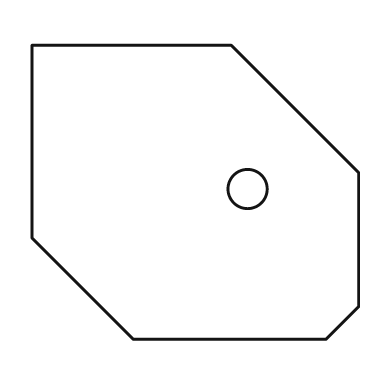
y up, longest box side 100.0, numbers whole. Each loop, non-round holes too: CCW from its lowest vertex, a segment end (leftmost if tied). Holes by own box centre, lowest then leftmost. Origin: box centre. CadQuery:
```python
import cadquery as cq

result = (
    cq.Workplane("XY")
    .moveTo(-19.0, -45.0)
    .lineTo(40.0, -45.0)
    .lineTo(50.0, -35.0)
    .lineTo(50.0, 6.0)
    .lineTo(11.0, 45.0)
    .lineTo(-50.0, 45.0)
    .lineTo(-50.0, -14.0)
    .close()
    .moveTo(16.0, 1.0)
    .circle(6.0)
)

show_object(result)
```